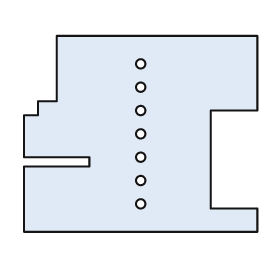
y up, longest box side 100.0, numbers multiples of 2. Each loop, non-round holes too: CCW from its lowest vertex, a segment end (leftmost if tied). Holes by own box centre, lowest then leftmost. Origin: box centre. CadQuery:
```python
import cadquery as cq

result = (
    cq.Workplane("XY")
    .moveTo(-50.0, -42.0)
    .lineTo(50.0, -42.0)
    .lineTo(50.0, -32.0)
    .lineTo(30.0, -32.0)
    .lineTo(30.0, 10.0)
    .lineTo(50.0, 10.0)
    .lineTo(50.0, 42.0)
    .lineTo(-36.0, 42.0)
    .lineTo(-36.0, 14.0)
    .lineTo(-44.0, 14.0)
    .lineTo(-44.0, 8.0)
    .lineTo(-50.0, 8.0)
    .lineTo(-50.0, -10.0)
    .lineTo(-22.0, -10.0)
    .lineTo(-22.0, -14.0)
    .lineTo(-50.0, -14.0)
    .close()
    .moveTo(0.0, -30.0)
    .circle(2.0)
    .moveTo(0.0, -20.0)
    .circle(2.0)
    .moveTo(0.0, -10.0)
    .circle(2.0)
    .moveTo(0.0, 0.0)
    .circle(2.0)
    .moveTo(0.0, 10.0)
    .circle(2.0)
    .moveTo(0.0, 20.0)
    .circle(2.0)
    .moveTo(0.0, 30.0)
    .circle(2.0)
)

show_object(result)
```